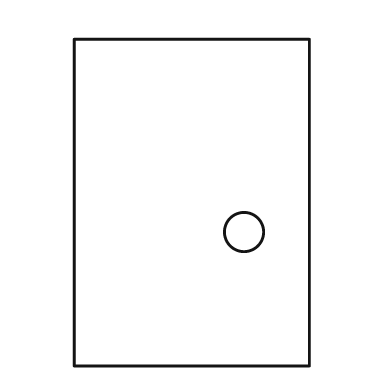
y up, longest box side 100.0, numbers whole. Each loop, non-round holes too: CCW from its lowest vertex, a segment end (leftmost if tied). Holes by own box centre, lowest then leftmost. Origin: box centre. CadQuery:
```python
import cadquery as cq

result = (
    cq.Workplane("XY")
    .moveTo(-36.0, -50.0)
    .lineTo(36.0, -50.0)
    .lineTo(36.0, 50.0)
    .lineTo(-36.0, 50.0)
    .close()
    .moveTo(16.0, -9.0)
    .circle(6.0)
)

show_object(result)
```